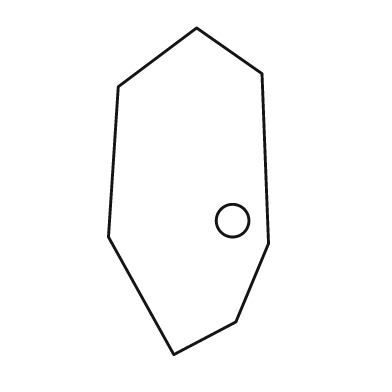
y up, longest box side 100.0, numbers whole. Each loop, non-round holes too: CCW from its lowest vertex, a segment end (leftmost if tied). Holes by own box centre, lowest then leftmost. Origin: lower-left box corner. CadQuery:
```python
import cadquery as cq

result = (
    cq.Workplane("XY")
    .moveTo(20.0, 0.0)
    .lineTo(39.0, 10.0)
    .lineTo(49.0, 34.0)
    .lineTo(47.0, 86.0)
    .lineTo(27.0, 100.0)
    .lineTo(3.0, 82.0)
    .lineTo(0.0, 36.0)
    .close()
    .moveTo(38.0, 41.0)
    .circle(5.0)
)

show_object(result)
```